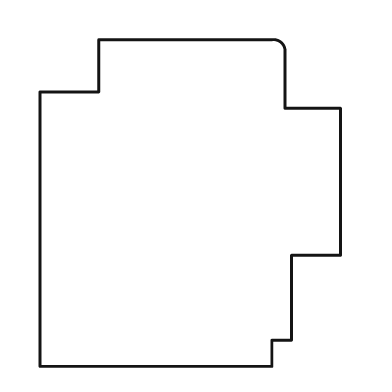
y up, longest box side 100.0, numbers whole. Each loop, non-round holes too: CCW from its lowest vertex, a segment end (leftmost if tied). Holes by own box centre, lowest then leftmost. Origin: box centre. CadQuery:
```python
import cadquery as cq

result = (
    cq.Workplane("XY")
    .moveTo(-46.0, -50.0)
    .lineTo(25.0, -50.0)
    .lineTo(25.0, -42.0)
    .lineTo(31.0, -42.0)
    .lineTo(31.0, -16.0)
    .lineTo(46.0, -16.0)
    .lineTo(46.0, 29.0)
    .lineTo(29.0, 29.0)
    .lineTo(29.0, 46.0)
    .threePointArc((28.0, 49.0), (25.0, 50.0))
    .lineTo(-28.0, 50.0)
    .lineTo(-28.0, 34.0)
    .lineTo(-46.0, 34.0)
    .close()
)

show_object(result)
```